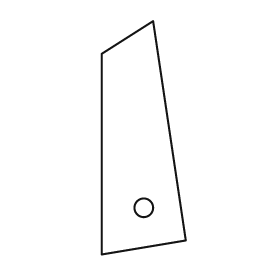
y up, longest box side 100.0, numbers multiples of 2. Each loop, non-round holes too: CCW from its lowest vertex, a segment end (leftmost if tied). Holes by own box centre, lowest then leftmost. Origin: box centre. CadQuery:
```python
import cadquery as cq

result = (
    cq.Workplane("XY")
    .moveTo(-18.0, -50.0)
    .lineTo(18.0, -44.0)
    .lineTo(4.0, 50.0)
    .lineTo(-18.0, 36.0)
    .close()
    .moveTo(0.0, -30.0)
    .circle(4.0)
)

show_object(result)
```